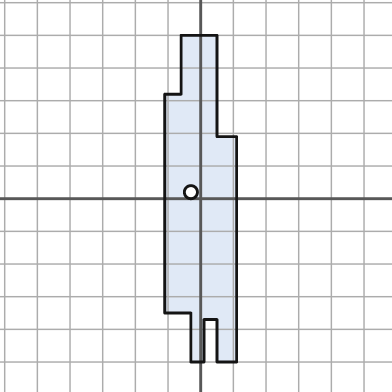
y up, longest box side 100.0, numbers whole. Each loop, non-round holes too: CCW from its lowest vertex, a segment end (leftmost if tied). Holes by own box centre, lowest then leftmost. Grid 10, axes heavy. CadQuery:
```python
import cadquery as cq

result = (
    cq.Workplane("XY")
    .moveTo(-3.0, -50.0)
    .lineTo(1.0, -50.0)
    .lineTo(1.0, -37.0)
    .lineTo(5.0, -37.0)
    .lineTo(5.0, -50.0)
    .lineTo(11.0, -50.0)
    .lineTo(11.0, 19.0)
    .lineTo(5.0, 19.0)
    .lineTo(5.0, 50.0)
    .lineTo(-6.0, 50.0)
    .lineTo(-6.0, 32.0)
    .lineTo(-11.0, 32.0)
    .lineTo(-11.0, -35.0)
    .lineTo(-3.0, -35.0)
    .close()
    .moveTo(-3.0, 2.0)
    .circle(2.0)
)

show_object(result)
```